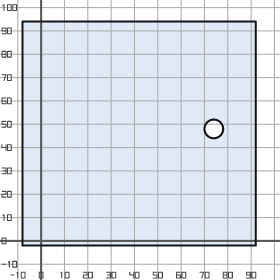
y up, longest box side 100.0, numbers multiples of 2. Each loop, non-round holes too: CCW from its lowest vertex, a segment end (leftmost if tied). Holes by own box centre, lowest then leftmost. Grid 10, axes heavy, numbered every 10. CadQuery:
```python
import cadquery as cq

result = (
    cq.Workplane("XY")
    .moveTo(-8.0, -2.0)
    .lineTo(92.0, -2.0)
    .lineTo(92.0, 94.0)
    .lineTo(-8.0, 94.0)
    .close()
    .moveTo(74.0, 48.0)
    .circle(4.0)
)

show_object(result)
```